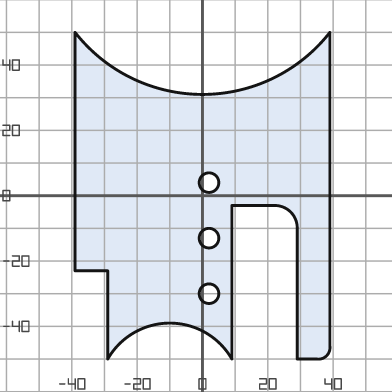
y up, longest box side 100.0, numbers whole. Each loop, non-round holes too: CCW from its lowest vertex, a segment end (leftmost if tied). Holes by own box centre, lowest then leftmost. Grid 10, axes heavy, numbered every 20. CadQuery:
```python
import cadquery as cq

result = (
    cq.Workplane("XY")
    .moveTo(-29.0, -50.0)
    .threePointArc((-10.0, -39.0), (9.0, -50.0))
    .lineTo(9.0, -3.0)
    .lineTo(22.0, -3.0)
    .threePointArc((27.0, -5.0), (29.0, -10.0))
    .lineTo(29.0, -50.0)
    .lineTo(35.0, -50.0)
    .threePointArc((38.0, -49.0), (39.0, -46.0))
    .lineTo(39.0, 50.0)
    .threePointArc((0.0, 31.0), (-39.0, 50.0))
    .lineTo(-39.0, -23.0)
    .lineTo(-29.0, -23.0)
    .close()
    .moveTo(2.0, -30.0)
    .circle(3.0)
    .moveTo(2.0, -13.0)
    .circle(3.0)
    .moveTo(2.0, 4.0)
    .circle(3.0)
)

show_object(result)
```